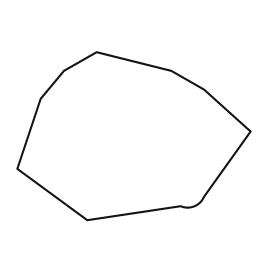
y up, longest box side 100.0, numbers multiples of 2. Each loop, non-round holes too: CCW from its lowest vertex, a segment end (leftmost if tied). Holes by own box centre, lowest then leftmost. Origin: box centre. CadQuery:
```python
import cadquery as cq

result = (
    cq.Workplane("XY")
    .moveTo(-20.0, -36.0)
    .lineTo(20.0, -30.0)
    .threePointArc((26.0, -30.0), (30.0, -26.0))
    .lineTo(50.0, 2.0)
    .lineTo(30.0, 20.0)
    .lineTo(16.0, 28.0)
    .lineTo(-16.0, 36.0)
    .lineTo(-30.0, 28.0)
    .lineTo(-40.0, 16.0)
    .lineTo(-50.0, -14.0)
    .close()
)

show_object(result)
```